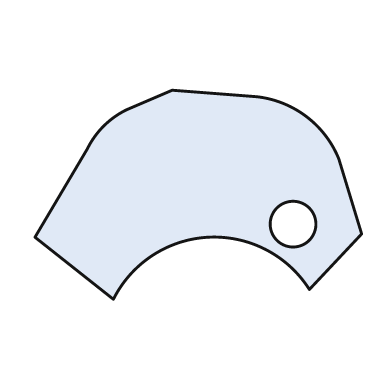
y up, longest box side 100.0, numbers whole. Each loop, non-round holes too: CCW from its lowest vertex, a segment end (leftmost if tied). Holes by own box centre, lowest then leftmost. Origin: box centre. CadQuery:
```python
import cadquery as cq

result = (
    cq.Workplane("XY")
    .moveTo(-26.0, -32.0)
    .threePointArc((3.0, -13.0), (34.0, -29.0))
    .lineTo(50.0, -12.0)
    .lineTo(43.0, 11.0)
    .threePointArc((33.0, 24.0), (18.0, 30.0))
    .lineTo(-8.0, 32.0)
    .lineTo(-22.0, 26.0)
    .threePointArc((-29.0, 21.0), (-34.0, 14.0))
    .lineTo(-50.0, -13.0)
    .close()
    .moveTo(29.0, -9.0)
    .circle(7.0)
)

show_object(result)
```